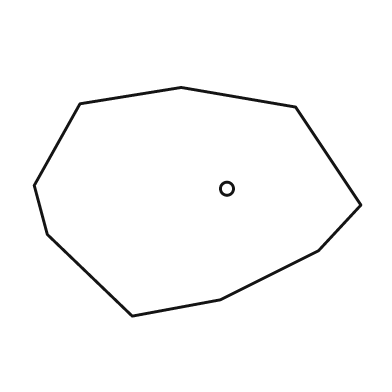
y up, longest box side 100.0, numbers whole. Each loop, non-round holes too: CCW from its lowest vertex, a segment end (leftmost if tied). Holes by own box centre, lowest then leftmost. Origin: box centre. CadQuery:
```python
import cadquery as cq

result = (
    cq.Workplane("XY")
    .moveTo(-20.0, -35.0)
    .lineTo(7.0, -30.0)
    .lineTo(37.0, -15.0)
    .lineTo(50.0, -1.0)
    .lineTo(30.0, 29.0)
    .lineTo(-5.0, 35.0)
    .lineTo(-36.0, 30.0)
    .lineTo(-50.0, 5.0)
    .lineTo(-46.0, -10.0)
    .close()
    .moveTo(9.0, 4.0)
    .circle(2.0)
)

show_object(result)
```